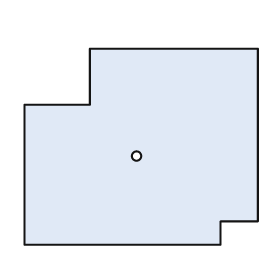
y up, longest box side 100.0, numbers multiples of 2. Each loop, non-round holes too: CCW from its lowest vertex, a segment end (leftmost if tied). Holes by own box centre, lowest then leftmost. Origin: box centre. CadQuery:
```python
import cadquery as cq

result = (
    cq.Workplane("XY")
    .moveTo(-50.0, -42.0)
    .lineTo(34.0, -42.0)
    .lineTo(34.0, -32.0)
    .lineTo(50.0, -32.0)
    .lineTo(50.0, 42.0)
    .lineTo(-22.0, 42.0)
    .lineTo(-22.0, 18.0)
    .lineTo(-50.0, 18.0)
    .close()
    .moveTo(-2.0, -4.0)
    .circle(2.0)
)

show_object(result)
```